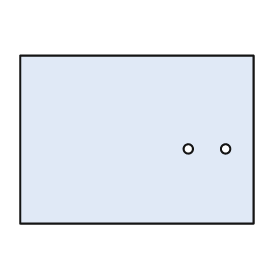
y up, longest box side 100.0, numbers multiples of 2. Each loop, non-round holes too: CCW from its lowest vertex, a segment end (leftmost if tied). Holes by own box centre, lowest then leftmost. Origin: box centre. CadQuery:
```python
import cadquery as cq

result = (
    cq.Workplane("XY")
    .moveTo(-50.0, -36.0)
    .lineTo(50.0, -36.0)
    .lineTo(50.0, 36.0)
    .lineTo(-50.0, 36.0)
    .close()
    .moveTo(22.0, -4.0)
    .circle(2.0)
    .moveTo(38.0, -4.0)
    .circle(2.0)
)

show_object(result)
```